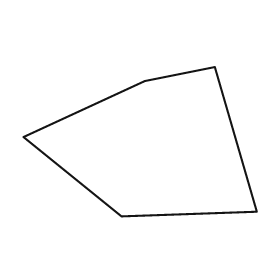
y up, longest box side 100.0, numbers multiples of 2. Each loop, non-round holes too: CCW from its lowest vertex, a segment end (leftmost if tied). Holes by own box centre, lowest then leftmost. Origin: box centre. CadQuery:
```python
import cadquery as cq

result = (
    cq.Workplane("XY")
    .moveTo(-8.0, -32.0)
    .lineTo(50.0, -30.0)
    .lineTo(32.0, 32.0)
    .lineTo(2.0, 26.0)
    .lineTo(-50.0, 2.0)
    .close()
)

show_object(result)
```